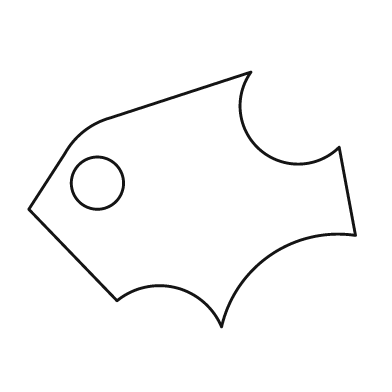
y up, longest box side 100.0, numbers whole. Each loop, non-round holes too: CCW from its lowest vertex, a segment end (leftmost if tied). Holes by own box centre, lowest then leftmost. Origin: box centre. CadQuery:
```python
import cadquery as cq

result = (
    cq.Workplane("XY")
    .moveTo(9.0, -39.0)
    .threePointArc((24.0, -17.0), (50.0, -11.0))
    .lineTo(45.0, 16.0)
    .threePointArc((21.0, 15.0), (18.0, 39.0))
    .lineTo(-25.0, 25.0)
    .threePointArc((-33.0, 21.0), (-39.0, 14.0))
    .lineTo(-50.0, -3.0)
    .lineTo(-23.0, -31.0)
    .threePointArc((-5.0, -27.0), (9.0, -39.0))
    .close()
    .moveTo(-29.0, 5.0)
    .circle(8.0)
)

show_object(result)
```